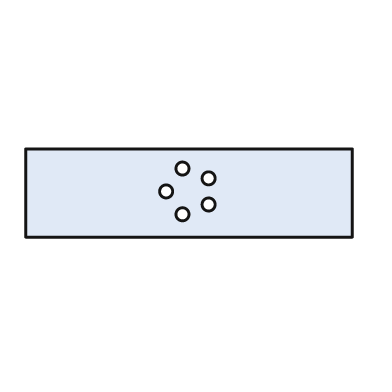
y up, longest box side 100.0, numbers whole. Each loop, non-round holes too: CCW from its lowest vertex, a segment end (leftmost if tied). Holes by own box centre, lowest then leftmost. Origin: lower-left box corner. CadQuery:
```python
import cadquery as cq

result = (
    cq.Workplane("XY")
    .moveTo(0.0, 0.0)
    .lineTo(100.0, 0.0)
    .lineTo(100.0, 27.0)
    .lineTo(0.0, 27.0)
    .close()
    .moveTo(48.0, 7.0)
    .circle(2.0)
    .moveTo(56.0, 10.0)
    .circle(2.0)
    .moveTo(43.0, 14.0)
    .circle(2.0)
    .moveTo(56.0, 18.0)
    .circle(2.0)
    .moveTo(48.0, 21.0)
    .circle(2.0)
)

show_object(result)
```